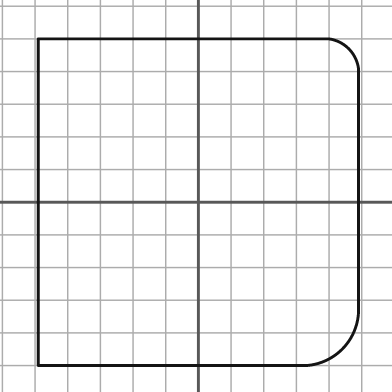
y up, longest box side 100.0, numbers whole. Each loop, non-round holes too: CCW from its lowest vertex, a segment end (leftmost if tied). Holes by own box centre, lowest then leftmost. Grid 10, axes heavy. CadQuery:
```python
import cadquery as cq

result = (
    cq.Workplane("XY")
    .moveTo(-49.0, -50.0)
    .lineTo(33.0, -50.0)
    .threePointArc((44.0, -45.0), (49.0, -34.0))
    .lineTo(49.0, 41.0)
    .threePointArc((46.0, 47.0), (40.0, 50.0))
    .lineTo(-49.0, 50.0)
    .close()
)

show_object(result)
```